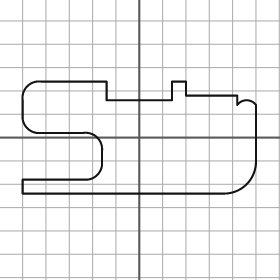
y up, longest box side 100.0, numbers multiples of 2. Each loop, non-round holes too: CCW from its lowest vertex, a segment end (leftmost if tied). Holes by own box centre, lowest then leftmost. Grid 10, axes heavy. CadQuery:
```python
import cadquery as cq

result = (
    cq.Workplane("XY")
    .moveTo(-50.0, -24.0)
    .lineTo(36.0, -24.0)
    .threePointArc((46.0, -20.0), (50.0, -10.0))
    .lineTo(50.0, 14.0)
    .threePointArc((46.0, 16.0), (42.0, 14.0))
    .lineTo(42.0, 18.0)
    .lineTo(20.0, 18.0)
    .lineTo(20.0, 24.0)
    .lineTo(14.0, 24.0)
    .lineTo(14.0, 16.0)
    .lineTo(-14.0, 16.0)
    .lineTo(-14.0, 24.0)
    .lineTo(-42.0, 24.0)
    .threePointArc((-48.0, 22.0), (-50.0, 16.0))
    .lineTo(-50.0, 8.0)
    .threePointArc((-48.0, 4.0), (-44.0, 2.0))
    .lineTo(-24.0, 2.0)
    .threePointArc((-18.0, 0.0), (-16.0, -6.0))
    .lineTo(-16.0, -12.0)
    .threePointArc((-18.0, -16.0), (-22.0, -18.0))
    .lineTo(-50.0, -18.0)
    .close()
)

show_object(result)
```